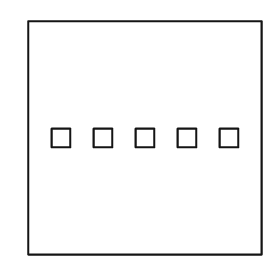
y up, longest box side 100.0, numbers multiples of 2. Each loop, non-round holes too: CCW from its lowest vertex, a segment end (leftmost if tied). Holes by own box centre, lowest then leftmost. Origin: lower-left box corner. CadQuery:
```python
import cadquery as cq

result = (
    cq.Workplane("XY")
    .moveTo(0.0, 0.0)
    .lineTo(100.0, 0.0)
    .lineTo(100.0, 100.0)
    .lineTo(0.0, 100.0)
    .close()
    .moveTo(10.0, 46.0)
    .lineTo(18.0, 46.0)
    .lineTo(18.0, 54.0)
    .lineTo(10.0, 54.0)
    .close()
    .moveTo(28.0, 46.0)
    .lineTo(36.0, 46.0)
    .lineTo(36.0, 54.0)
    .lineTo(28.0, 54.0)
    .close()
    .moveTo(46.0, 46.0)
    .lineTo(54.0, 46.0)
    .lineTo(54.0, 54.0)
    .lineTo(46.0, 54.0)
    .close()
    .moveTo(64.0, 46.0)
    .lineTo(72.0, 46.0)
    .lineTo(72.0, 54.0)
    .lineTo(64.0, 54.0)
    .close()
    .moveTo(82.0, 46.0)
    .lineTo(90.0, 46.0)
    .lineTo(90.0, 54.0)
    .lineTo(82.0, 54.0)
    .close()
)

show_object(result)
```